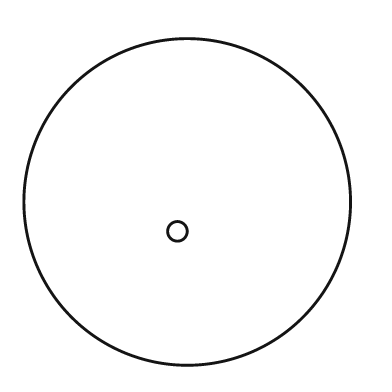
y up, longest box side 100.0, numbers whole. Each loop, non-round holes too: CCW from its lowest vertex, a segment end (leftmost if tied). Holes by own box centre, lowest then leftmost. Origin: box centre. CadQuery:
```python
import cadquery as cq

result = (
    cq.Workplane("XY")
    .moveTo(0.0, 0.0)
    .circle(50.0)
    .moveTo(-3.0, -9.0)
    .circle(3.0)
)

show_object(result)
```